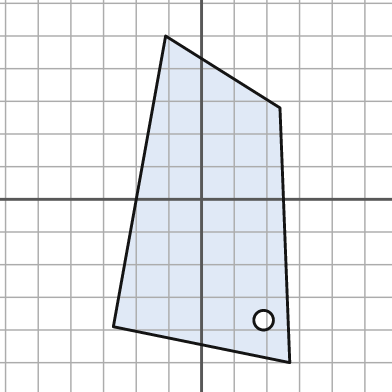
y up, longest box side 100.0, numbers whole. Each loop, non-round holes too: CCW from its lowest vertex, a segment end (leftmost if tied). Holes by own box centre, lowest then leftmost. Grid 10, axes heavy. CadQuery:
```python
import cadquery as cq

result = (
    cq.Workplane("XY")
    .moveTo(27.0, -50.0)
    .lineTo(24.0, 28.0)
    .lineTo(-11.0, 50.0)
    .lineTo(-27.0, -39.0)
    .close()
    .moveTo(19.0, -37.0)
    .circle(3.0)
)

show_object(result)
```